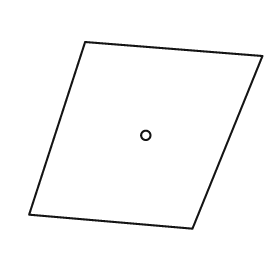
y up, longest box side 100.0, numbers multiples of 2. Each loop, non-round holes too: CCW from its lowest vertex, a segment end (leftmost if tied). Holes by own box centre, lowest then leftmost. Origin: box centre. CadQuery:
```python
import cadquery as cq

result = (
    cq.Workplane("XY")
    .moveTo(20.0, -40.0)
    .lineTo(50.0, 34.0)
    .lineTo(-26.0, 40.0)
    .lineTo(-50.0, -34.0)
    .close()
    .moveTo(0.0, 0.0)
    .circle(2.0)
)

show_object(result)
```